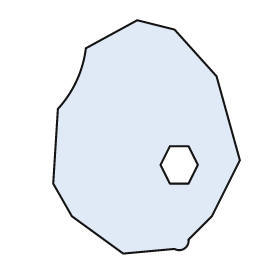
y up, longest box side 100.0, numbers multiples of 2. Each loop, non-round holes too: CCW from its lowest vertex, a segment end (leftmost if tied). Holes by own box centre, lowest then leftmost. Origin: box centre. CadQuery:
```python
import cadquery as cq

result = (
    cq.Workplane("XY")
    .moveTo(-10.0, -50.0)
    .lineTo(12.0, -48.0)
    .threePointArc((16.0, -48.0), (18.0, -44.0))
    .lineTo(28.0, -34.0)
    .lineTo(40.0, -10.0)
    .lineTo(30.0, 26.0)
    .lineTo(12.0, 46.0)
    .lineTo(-4.0, 50.0)
    .lineTo(-26.0, 38.0)
    .threePointArc((-30.0, 24.0), (-38.0, 12.0))
    .lineTo(-40.0, -20.0)
    .lineTo(-32.0, -34.0)
    .close()
    .moveTo(10.0, -20.0)
    .lineTo(18.0, -20.0)
    .lineTo(22.0, -12.0)
    .lineTo(18.0, -4.0)
    .lineTo(10.0, -4.0)
    .lineTo(6.0, -12.0)
    .close()
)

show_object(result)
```